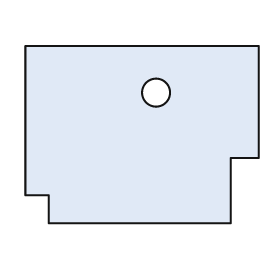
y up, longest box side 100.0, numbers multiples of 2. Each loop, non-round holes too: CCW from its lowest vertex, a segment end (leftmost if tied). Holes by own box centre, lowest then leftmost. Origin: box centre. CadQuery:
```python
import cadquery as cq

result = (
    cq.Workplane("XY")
    .moveTo(-40.0, -38.0)
    .lineTo(38.0, -38.0)
    .lineTo(38.0, -10.0)
    .lineTo(50.0, -10.0)
    .lineTo(50.0, 38.0)
    .lineTo(-50.0, 38.0)
    .lineTo(-50.0, -26.0)
    .lineTo(-40.0, -26.0)
    .close()
    .moveTo(6.0, 18.0)
    .circle(6.0)
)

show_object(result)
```